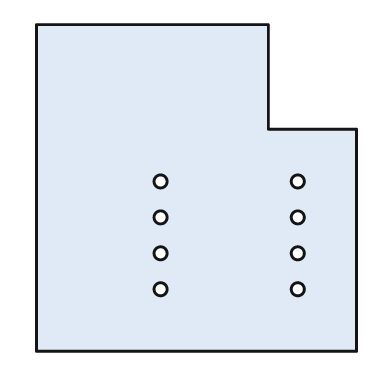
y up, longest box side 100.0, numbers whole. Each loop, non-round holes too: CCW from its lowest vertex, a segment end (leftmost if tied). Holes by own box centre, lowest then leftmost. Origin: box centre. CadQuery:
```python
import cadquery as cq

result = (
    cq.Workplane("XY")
    .moveTo(-49.0, -50.0)
    .lineTo(49.0, -50.0)
    .lineTo(49.0, 18.0)
    .lineTo(22.0, 18.0)
    .lineTo(22.0, 50.0)
    .lineTo(-49.0, 50.0)
    .close()
    .moveTo(-11.0, -31.0)
    .circle(2.0)
    .moveTo(31.0, -31.0)
    .circle(2.0)
    .moveTo(-11.0, -20.0)
    .circle(2.0)
    .moveTo(31.0, -20.0)
    .circle(2.0)
    .moveTo(-11.0, -9.0)
    .circle(2.0)
    .moveTo(31.0, -9.0)
    .circle(2.0)
    .moveTo(-11.0, 2.0)
    .circle(2.0)
    .moveTo(31.0, 2.0)
    .circle(2.0)
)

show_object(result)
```